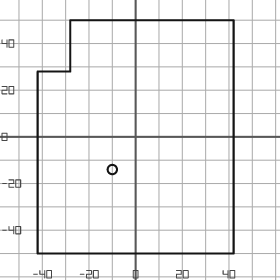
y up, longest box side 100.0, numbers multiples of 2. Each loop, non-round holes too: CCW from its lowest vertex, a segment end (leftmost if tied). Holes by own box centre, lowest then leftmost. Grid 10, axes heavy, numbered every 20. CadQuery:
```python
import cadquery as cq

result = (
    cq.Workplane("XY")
    .moveTo(-42.0, -50.0)
    .lineTo(42.0, -50.0)
    .lineTo(42.0, 50.0)
    .lineTo(-28.0, 50.0)
    .lineTo(-28.0, 28.0)
    .lineTo(-42.0, 28.0)
    .close()
    .moveTo(-10.0, -14.0)
    .circle(2.0)
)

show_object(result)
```